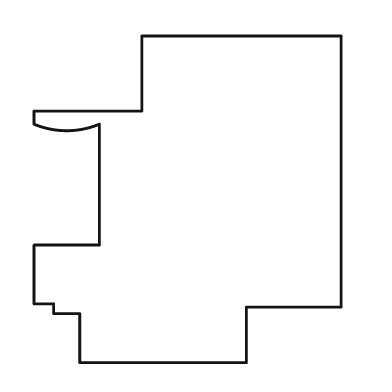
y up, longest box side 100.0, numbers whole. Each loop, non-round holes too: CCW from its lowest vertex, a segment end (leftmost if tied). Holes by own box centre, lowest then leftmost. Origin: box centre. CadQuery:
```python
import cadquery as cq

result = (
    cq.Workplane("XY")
    .moveTo(-33.0, -50.0)
    .lineTo(18.0, -50.0)
    .lineTo(18.0, -33.0)
    .lineTo(47.0, -33.0)
    .lineTo(47.0, 50.0)
    .lineTo(-14.0, 50.0)
    .lineTo(-14.0, 27.0)
    .lineTo(-47.0, 27.0)
    .lineTo(-47.0, 23.0)
    .threePointArc((-37.0, 21.0), (-27.0, 23.0))
    .lineTo(-27.0, -14.0)
    .lineTo(-47.0, -14.0)
    .lineTo(-47.0, -32.0)
    .lineTo(-41.0, -32.0)
    .lineTo(-41.0, -35.0)
    .lineTo(-33.0, -35.0)
    .close()
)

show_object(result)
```